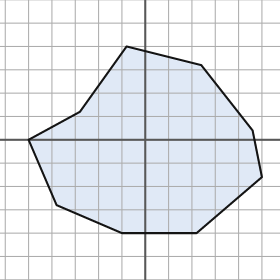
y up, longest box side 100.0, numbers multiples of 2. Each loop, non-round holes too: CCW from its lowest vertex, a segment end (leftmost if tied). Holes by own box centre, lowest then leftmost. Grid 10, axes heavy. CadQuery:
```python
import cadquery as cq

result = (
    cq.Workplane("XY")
    .moveTo(-10.0, -40.0)
    .lineTo(22.0, -40.0)
    .lineTo(50.0, -16.0)
    .lineTo(46.0, 4.0)
    .lineTo(24.0, 32.0)
    .lineTo(-8.0, 40.0)
    .lineTo(-28.0, 12.0)
    .lineTo(-50.0, 0.0)
    .lineTo(-38.0, -28.0)
    .close()
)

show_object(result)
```